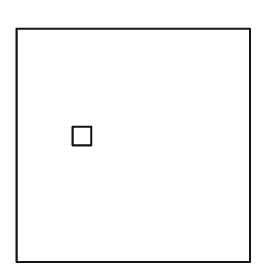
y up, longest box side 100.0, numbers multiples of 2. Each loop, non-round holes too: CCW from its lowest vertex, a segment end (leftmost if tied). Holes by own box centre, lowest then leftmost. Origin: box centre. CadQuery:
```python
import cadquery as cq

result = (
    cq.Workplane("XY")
    .moveTo(-50.0, -50.0)
    .lineTo(50.0, -50.0)
    .lineTo(50.0, 50.0)
    .lineTo(-50.0, 50.0)
    .close()
    .moveTo(-26.0, 0.0)
    .lineTo(-18.0, 0.0)
    .lineTo(-18.0, 8.0)
    .lineTo(-26.0, 8.0)
    .close()
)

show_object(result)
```